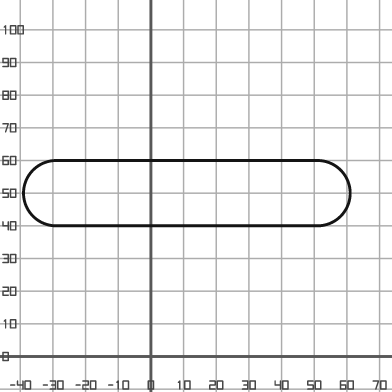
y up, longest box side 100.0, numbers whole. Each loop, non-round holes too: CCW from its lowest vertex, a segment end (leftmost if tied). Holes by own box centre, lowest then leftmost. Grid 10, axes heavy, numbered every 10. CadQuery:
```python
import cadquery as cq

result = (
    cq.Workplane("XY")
    .moveTo(-29.0, 40.0)
    .lineTo(51.0, 40.0)
    .threePointArc((61.0, 50.0), (51.0, 60.0))
    .lineTo(-29.0, 60.0)
    .threePointArc((-39.0, 50.0), (-29.0, 40.0))
    .close()
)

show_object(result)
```